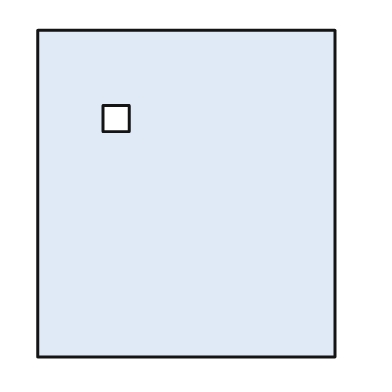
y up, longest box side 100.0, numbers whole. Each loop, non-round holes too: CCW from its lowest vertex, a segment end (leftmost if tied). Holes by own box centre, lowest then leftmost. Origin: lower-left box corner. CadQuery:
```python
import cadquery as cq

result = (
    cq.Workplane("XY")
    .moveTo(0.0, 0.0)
    .lineTo(91.0, 0.0)
    .lineTo(91.0, 100.0)
    .lineTo(0.0, 100.0)
    .close()
    .moveTo(20.0, 69.0)
    .lineTo(28.0, 69.0)
    .lineTo(28.0, 77.0)
    .lineTo(20.0, 77.0)
    .close()
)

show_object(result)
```